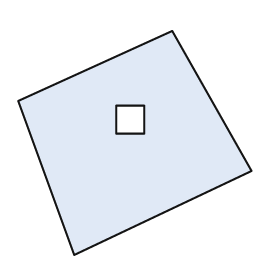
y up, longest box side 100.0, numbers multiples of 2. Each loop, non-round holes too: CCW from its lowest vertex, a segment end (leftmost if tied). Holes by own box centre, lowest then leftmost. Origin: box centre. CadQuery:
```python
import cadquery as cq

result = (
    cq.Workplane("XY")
    .moveTo(-26.0, -48.0)
    .lineTo(50.0, -12.0)
    .lineTo(16.0, 48.0)
    .lineTo(-50.0, 18.0)
    .close()
    .moveTo(-8.0, 4.0)
    .lineTo(4.0, 4.0)
    .lineTo(4.0, 16.0)
    .lineTo(-8.0, 16.0)
    .close()
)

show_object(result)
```